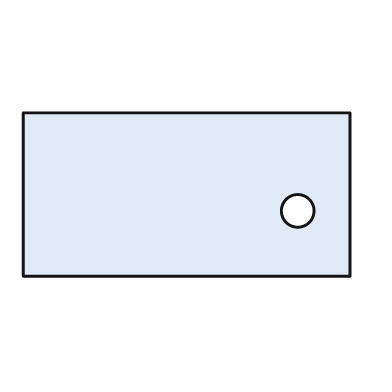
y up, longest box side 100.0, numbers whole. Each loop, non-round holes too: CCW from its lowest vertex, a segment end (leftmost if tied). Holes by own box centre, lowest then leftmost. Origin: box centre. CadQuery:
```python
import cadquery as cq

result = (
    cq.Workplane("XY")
    .moveTo(-50.0, -25.0)
    .lineTo(50.0, -25.0)
    .lineTo(50.0, 25.0)
    .lineTo(-50.0, 25.0)
    .close()
    .moveTo(34.0, -5.0)
    .circle(5.0)
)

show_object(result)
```